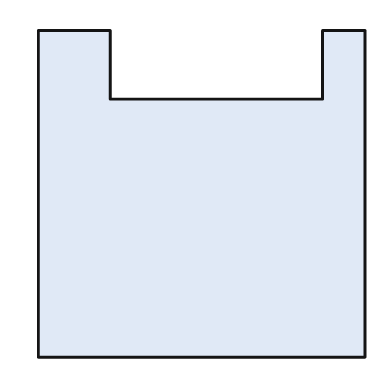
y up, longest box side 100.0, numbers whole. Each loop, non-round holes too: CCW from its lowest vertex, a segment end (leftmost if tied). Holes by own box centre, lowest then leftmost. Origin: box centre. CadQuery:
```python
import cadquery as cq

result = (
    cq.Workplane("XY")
    .moveTo(-50.0, -50.0)
    .lineTo(50.0, -50.0)
    .lineTo(50.0, 50.0)
    .lineTo(37.0, 50.0)
    .lineTo(37.0, 29.0)
    .lineTo(-28.0, 29.0)
    .lineTo(-28.0, 50.0)
    .lineTo(-50.0, 50.0)
    .close()
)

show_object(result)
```